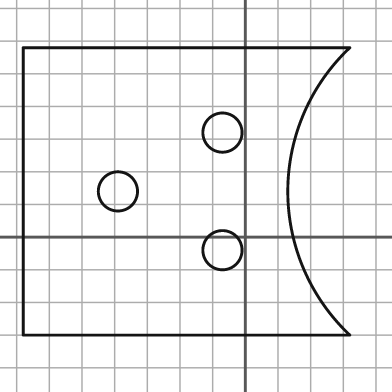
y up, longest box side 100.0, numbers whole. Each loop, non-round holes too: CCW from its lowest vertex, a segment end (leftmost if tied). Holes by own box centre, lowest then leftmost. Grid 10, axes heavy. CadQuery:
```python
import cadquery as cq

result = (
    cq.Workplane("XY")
    .moveTo(-68.0, -30.0)
    .lineTo(32.0, -30.0)
    .threePointArc((13.0, 14.0), (32.0, 58.0))
    .lineTo(-68.0, 58.0)
    .close()
    .moveTo(-7.0, -4.0)
    .circle(6.0)
    .moveTo(-39.0, 14.0)
    .circle(6.0)
    .moveTo(-7.0, 32.0)
    .circle(6.0)
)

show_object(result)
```